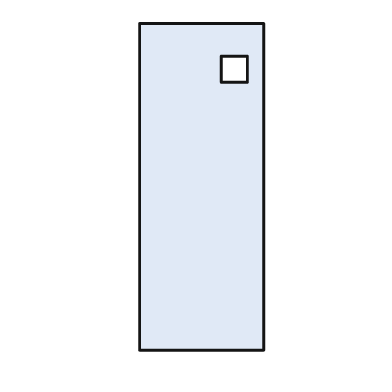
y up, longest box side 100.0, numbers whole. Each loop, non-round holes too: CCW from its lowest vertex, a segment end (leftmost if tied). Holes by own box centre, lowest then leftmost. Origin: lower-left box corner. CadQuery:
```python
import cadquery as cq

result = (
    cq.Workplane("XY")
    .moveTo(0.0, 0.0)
    .lineTo(38.0, 0.0)
    .lineTo(38.0, 100.0)
    .lineTo(0.0, 100.0)
    .close()
    .moveTo(25.0, 82.0)
    .lineTo(33.0, 82.0)
    .lineTo(33.0, 90.0)
    .lineTo(25.0, 90.0)
    .close()
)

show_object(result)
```